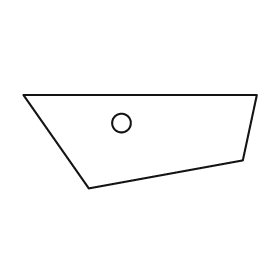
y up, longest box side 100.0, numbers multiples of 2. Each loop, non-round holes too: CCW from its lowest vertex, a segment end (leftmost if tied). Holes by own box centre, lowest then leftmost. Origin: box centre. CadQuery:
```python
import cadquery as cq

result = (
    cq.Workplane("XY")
    .moveTo(-22.0, -20.0)
    .lineTo(44.0, -8.0)
    .lineTo(50.0, 20.0)
    .lineTo(-50.0, 20.0)
    .close()
    .moveTo(-8.0, 8.0)
    .circle(4.0)
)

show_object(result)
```